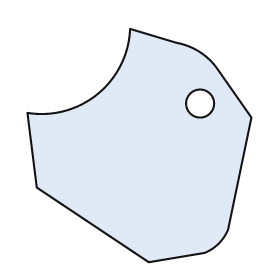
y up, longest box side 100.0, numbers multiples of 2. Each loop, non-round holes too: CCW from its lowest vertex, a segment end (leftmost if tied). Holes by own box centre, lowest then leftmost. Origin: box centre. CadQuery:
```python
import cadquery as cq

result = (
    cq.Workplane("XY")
    .moveTo(4.0, -50.0)
    .lineTo(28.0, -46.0)
    .threePointArc((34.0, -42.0), (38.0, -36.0))
    .lineTo(48.0, 12.0)
    .lineTo(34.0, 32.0)
    .threePointArc((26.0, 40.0), (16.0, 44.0))
    .lineTo(-4.0, 50.0)
    .threePointArc((-18.0, 22.0), (-48.0, 14.0))
    .lineTo(-44.0, -18.0)
    .close()
    .moveTo(26.0, 18.0)
    .circle(6.0)
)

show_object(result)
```